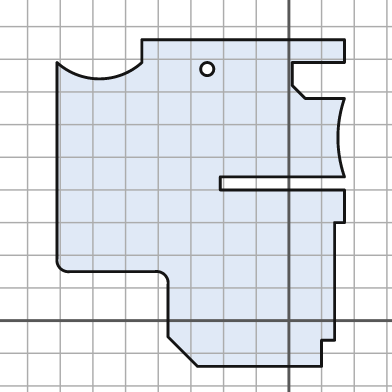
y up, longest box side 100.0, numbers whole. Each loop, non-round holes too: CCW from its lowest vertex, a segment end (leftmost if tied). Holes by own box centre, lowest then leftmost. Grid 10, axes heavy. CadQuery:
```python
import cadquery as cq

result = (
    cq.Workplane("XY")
    .moveTo(-28.0, -14.0)
    .lineTo(10.0, -14.0)
    .lineTo(10.0, -6.0)
    .lineTo(14.0, -6.0)
    .lineTo(14.0, 30.0)
    .lineTo(17.0, 30.0)
    .lineTo(17.0, 40.0)
    .lineTo(-21.0, 40.0)
    .lineTo(-21.0, 44.0)
    .lineTo(17.0, 44.0)
    .threePointArc((15.0, 56.0), (17.0, 68.0))
    .lineTo(5.0, 68.0)
    .lineTo(1.0, 72.0)
    .lineTo(1.0, 79.0)
    .lineTo(17.0, 79.0)
    .lineTo(17.0, 86.0)
    .lineTo(-45.0, 86.0)
    .lineTo(-45.0, 79.0)
    .threePointArc((-58.0, 74.0), (-71.0, 79.0))
    .lineTo(-71.0, 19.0)
    .threePointArc((-70.0, 16.0), (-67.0, 15.0))
    .lineTo(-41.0, 15.0)
    .threePointArc((-38.0, 14.0), (-37.0, 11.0))
    .lineTo(-37.0, -5.0)
    .close()
    .moveTo(-25.0, 77.0)
    .circle(2.0)
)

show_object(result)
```